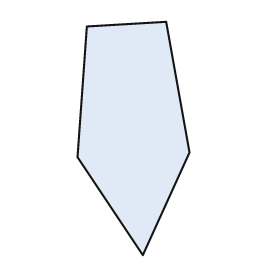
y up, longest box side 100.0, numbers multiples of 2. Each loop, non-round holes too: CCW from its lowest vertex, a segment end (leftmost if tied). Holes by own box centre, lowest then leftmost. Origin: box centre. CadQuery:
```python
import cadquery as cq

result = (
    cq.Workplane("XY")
    .moveTo(4.0, -50.0)
    .lineTo(24.0, -6.0)
    .lineTo(14.0, 50.0)
    .lineTo(-20.0, 48.0)
    .lineTo(-24.0, -8.0)
    .close()
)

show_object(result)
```